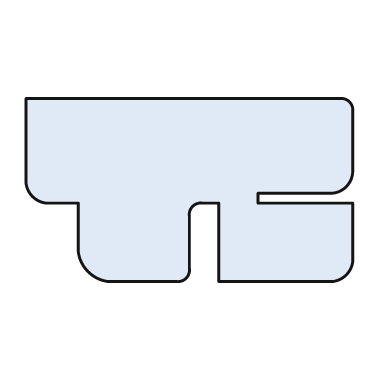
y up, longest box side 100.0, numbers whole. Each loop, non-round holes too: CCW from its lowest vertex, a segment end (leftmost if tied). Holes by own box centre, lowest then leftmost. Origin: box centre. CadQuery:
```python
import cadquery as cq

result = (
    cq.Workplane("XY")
    .moveTo(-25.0, -28.0)
    .lineTo(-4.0, -28.0)
    .threePointArc((-1.0, -27.0), (0.0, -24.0))
    .lineTo(0.0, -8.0)
    .threePointArc((1.0, -5.0), (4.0, -4.0))
    .lineTo(9.0, -4.0)
    .lineTo(9.0, -28.0)
    .lineTo(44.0, -28.0)
    .threePointArc((48.0, -26.0), (50.0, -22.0))
    .lineTo(50.0, -4.0)
    .lineTo(21.0, -4.0)
    .lineTo(21.0, -1.0)
    .lineTo(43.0, -1.0)
    .threePointArc((48.0, 1.0), (50.0, 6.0))
    .lineTo(50.0, 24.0)
    .threePointArc((49.0, 27.0), (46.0, 28.0))
    .lineTo(-50.0, 28.0)
    .lineTo(-50.0, 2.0)
    .threePointArc((-48.0, -2.0), (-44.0, -4.0))
    .lineTo(-34.0, -4.0)
    .lineTo(-34.0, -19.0)
    .threePointArc((-31.0, -25.0), (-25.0, -28.0))
    .close()
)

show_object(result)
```